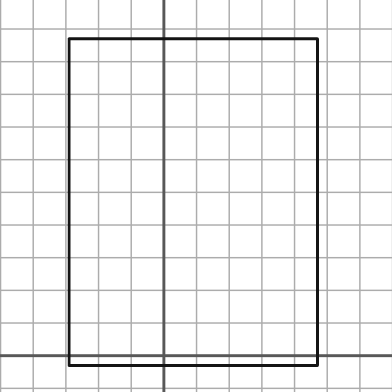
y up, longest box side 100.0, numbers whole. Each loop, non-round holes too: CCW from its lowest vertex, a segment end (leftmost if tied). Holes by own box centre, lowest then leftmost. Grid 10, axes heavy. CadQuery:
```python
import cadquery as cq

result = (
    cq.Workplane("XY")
    .moveTo(-29.0, -3.0)
    .lineTo(47.0, -3.0)
    .lineTo(47.0, 97.0)
    .lineTo(-29.0, 97.0)
    .close()
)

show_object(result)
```